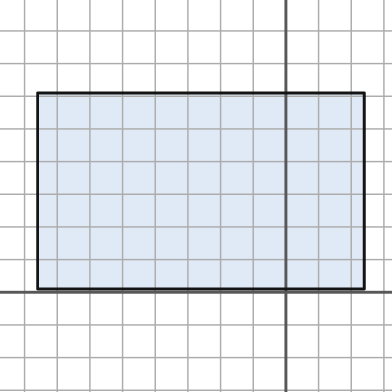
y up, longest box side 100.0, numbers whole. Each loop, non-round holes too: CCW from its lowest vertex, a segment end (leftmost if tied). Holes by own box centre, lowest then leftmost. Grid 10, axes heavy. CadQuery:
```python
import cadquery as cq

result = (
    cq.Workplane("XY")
    .moveTo(-76.0, 1.0)
    .lineTo(24.0, 1.0)
    .lineTo(24.0, 61.0)
    .lineTo(-76.0, 61.0)
    .close()
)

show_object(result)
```